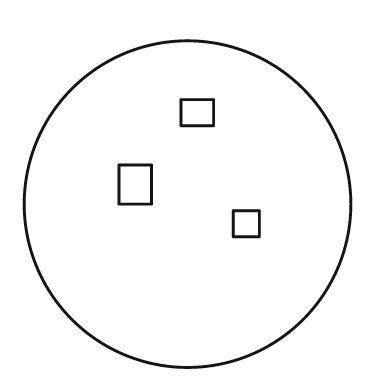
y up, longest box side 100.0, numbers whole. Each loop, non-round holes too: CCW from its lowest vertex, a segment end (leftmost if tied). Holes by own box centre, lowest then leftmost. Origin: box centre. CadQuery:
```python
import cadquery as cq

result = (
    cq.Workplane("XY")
    .moveTo(0.0, 0.0)
    .circle(50.0)
    .moveTo(14.0, -10.0)
    .lineTo(22.0, -10.0)
    .lineTo(22.0, -2.0)
    .lineTo(14.0, -2.0)
    .close()
    .moveTo(-21.0, 0.0)
    .lineTo(-11.0, 0.0)
    .lineTo(-11.0, 12.0)
    .lineTo(-21.0, 12.0)
    .close()
    .moveTo(-2.0, 24.0)
    .lineTo(8.0, 24.0)
    .lineTo(8.0, 32.0)
    .lineTo(-2.0, 32.0)
    .close()
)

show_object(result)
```